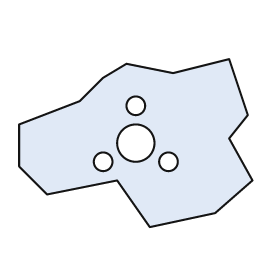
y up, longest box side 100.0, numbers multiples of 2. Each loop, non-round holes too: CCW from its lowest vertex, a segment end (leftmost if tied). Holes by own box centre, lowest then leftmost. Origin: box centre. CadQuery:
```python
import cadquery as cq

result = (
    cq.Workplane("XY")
    .moveTo(6.0, -36.0)
    .lineTo(34.0, -30.0)
    .lineTo(50.0, -16.0)
    .lineTo(40.0, 2.0)
    .lineTo(48.0, 12.0)
    .lineTo(40.0, 36.0)
    .lineTo(16.0, 30.0)
    .lineTo(-4.0, 34.0)
    .lineTo(-14.0, 28.0)
    .lineTo(-24.0, 18.0)
    .lineTo(-50.0, 8.0)
    .lineTo(-50.0, -10.0)
    .lineTo(-38.0, -22.0)
    .lineTo(-8.0, -16.0)
    .close()
    .moveTo(-14.0, -8.0)
    .circle(4.0)
    .moveTo(14.0, -8.0)
    .circle(4.0)
    .moveTo(0.0, 0.0)
    .circle(8.0)
    .moveTo(0.0, 16.0)
    .circle(4.0)
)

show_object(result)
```